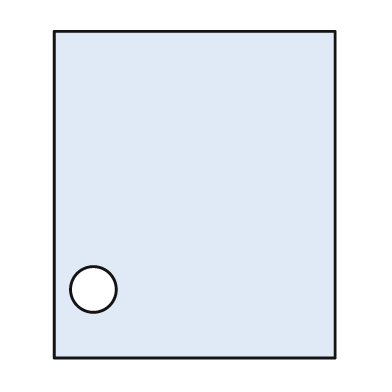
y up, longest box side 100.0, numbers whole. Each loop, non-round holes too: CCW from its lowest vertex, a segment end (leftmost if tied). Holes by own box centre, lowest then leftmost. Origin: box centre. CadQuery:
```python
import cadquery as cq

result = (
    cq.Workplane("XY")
    .moveTo(-43.0, -50.0)
    .lineTo(43.0, -50.0)
    .lineTo(43.0, 50.0)
    .lineTo(-43.0, 50.0)
    .close()
    .moveTo(-31.0, -29.0)
    .circle(7.0)
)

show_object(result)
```